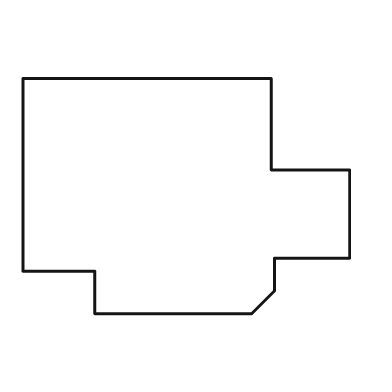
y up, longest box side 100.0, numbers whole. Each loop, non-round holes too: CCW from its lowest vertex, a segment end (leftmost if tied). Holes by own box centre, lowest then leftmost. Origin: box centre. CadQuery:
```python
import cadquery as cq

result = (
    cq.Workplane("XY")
    .moveTo(-28.0, -36.0)
    .lineTo(20.0, -36.0)
    .lineTo(27.0, -29.0)
    .lineTo(27.0, -19.0)
    .lineTo(50.0, -19.0)
    .lineTo(50.0, 8.0)
    .lineTo(26.0, 8.0)
    .lineTo(26.0, 36.0)
    .lineTo(-50.0, 36.0)
    .lineTo(-50.0, -23.0)
    .lineTo(-28.0, -23.0)
    .close()
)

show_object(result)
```